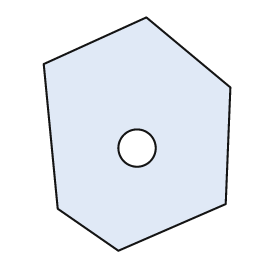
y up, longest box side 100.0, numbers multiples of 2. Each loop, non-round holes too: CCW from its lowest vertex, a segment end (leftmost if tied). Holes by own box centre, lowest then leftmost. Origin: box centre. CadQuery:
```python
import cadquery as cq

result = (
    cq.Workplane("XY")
    .moveTo(-8.0, -50.0)
    .lineTo(38.0, -30.0)
    .lineTo(40.0, 20.0)
    .lineTo(4.0, 50.0)
    .lineTo(-40.0, 30.0)
    .lineTo(-34.0, -32.0)
    .close()
    .moveTo(0.0, -6.0)
    .circle(8.0)
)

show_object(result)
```